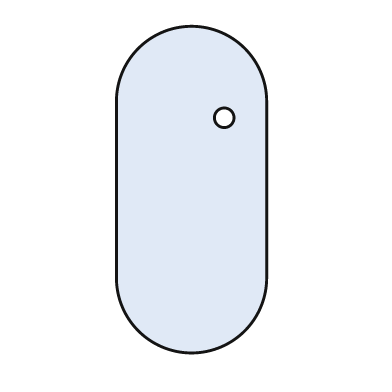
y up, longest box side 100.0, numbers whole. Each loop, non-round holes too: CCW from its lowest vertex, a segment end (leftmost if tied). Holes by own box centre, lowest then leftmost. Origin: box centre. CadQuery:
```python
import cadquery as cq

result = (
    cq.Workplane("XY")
    .moveTo(-23.0, -27.0)
    .threePointArc((0.0, -50.0), (23.0, -27.0))
    .lineTo(23.0, 27.0)
    .threePointArc((0.0, 50.0), (-23.0, 27.0))
    .close()
    .moveTo(10.0, 22.0)
    .circle(3.0)
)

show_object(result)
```